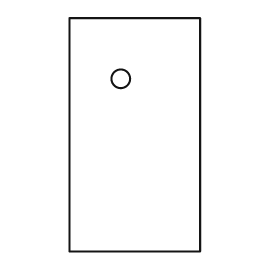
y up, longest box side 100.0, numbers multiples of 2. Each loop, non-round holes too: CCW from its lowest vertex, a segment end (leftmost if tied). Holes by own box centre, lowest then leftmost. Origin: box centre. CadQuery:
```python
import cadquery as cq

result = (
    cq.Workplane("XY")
    .moveTo(-28.0, -50.0)
    .lineTo(28.0, -50.0)
    .lineTo(28.0, 50.0)
    .lineTo(-28.0, 50.0)
    .close()
    .moveTo(-6.0, 24.0)
    .circle(4.0)
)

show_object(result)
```